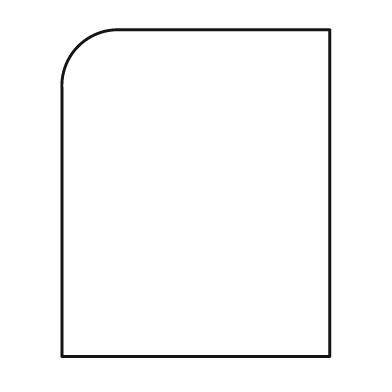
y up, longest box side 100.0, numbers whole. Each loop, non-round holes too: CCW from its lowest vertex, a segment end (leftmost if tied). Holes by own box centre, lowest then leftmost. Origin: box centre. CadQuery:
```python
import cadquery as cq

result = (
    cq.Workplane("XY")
    .moveTo(-41.0, -50.0)
    .lineTo(41.0, -50.0)
    .lineTo(41.0, 50.0)
    .lineTo(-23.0, 50.0)
    .threePointArc((-36.0, 45.0), (-41.0, 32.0))
    .close()
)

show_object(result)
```